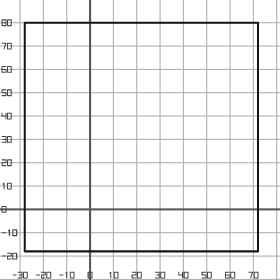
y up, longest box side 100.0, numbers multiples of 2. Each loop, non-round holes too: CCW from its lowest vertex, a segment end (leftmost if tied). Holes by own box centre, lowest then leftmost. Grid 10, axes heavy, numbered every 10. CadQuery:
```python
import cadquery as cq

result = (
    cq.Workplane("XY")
    .moveTo(-28.0, -18.0)
    .lineTo(72.0, -18.0)
    .lineTo(72.0, 80.0)
    .lineTo(-28.0, 80.0)
    .close()
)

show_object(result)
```